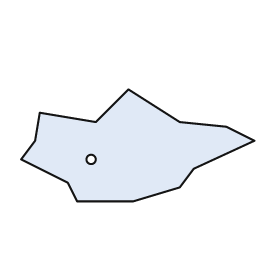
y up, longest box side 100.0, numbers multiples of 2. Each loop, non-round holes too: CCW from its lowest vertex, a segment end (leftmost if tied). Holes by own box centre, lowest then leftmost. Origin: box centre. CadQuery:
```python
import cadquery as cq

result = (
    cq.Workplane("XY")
    .moveTo(-26.0, -24.0)
    .lineTo(-2.0, -24.0)
    .lineTo(18.0, -18.0)
    .lineTo(24.0, -10.0)
    .lineTo(50.0, 2.0)
    .lineTo(38.0, 8.0)
    .lineTo(18.0, 10.0)
    .lineTo(-4.0, 24.0)
    .lineTo(-18.0, 10.0)
    .lineTo(-42.0, 14.0)
    .lineTo(-44.0, 2.0)
    .lineTo(-50.0, -6.0)
    .lineTo(-30.0, -16.0)
    .close()
    .moveTo(-20.0, -6.0)
    .circle(2.0)
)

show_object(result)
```